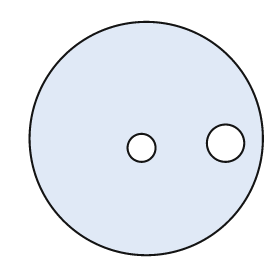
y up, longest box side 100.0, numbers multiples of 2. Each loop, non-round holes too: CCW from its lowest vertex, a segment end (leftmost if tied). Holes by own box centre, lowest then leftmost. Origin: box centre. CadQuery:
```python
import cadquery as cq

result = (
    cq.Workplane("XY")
    .moveTo(0.0, 0.0)
    .circle(50.0)
    .moveTo(-2.0, -4.0)
    .circle(6.0)
    .moveTo(34.0, -2.0)
    .circle(8.0)
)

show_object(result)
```